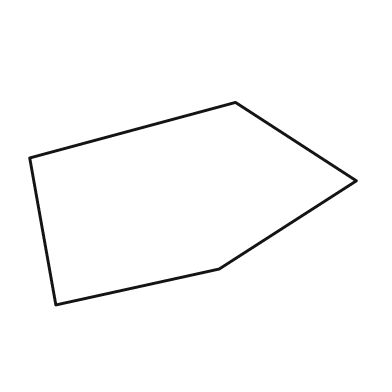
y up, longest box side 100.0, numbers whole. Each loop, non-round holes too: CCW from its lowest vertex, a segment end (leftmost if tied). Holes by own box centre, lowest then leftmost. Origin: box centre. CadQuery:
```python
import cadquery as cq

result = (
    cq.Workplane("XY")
    .moveTo(-42.0, -31.0)
    .lineTo(8.0, -20.0)
    .lineTo(50.0, 7.0)
    .lineTo(13.0, 31.0)
    .lineTo(-50.0, 14.0)
    .close()
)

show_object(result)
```